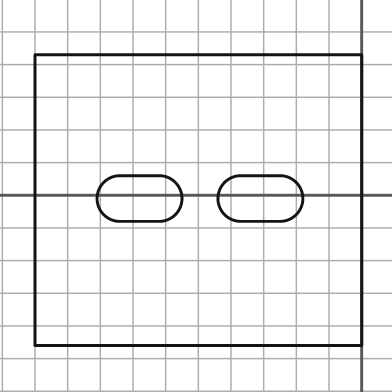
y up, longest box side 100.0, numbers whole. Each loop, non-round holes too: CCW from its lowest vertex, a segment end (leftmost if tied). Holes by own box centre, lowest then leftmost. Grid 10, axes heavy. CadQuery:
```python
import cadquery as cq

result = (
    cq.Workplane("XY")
    .moveTo(-100.0, -46.0)
    .lineTo(0.0, -46.0)
    .lineTo(0.0, 43.0)
    .lineTo(-100.0, 43.0)
    .close()
    .moveTo(-74.0, -8.0)
    .lineTo(-62.0, -8.0)
    .threePointArc((-55.0, -1.0), (-62.0, 6.0))
    .lineTo(-74.0, 6.0)
    .threePointArc((-81.0, -1.0), (-74.0, -8.0))
    .close()
    .moveTo(-37.0, -8.0)
    .lineTo(-25.0, -8.0)
    .threePointArc((-18.0, -1.0), (-25.0, 6.0))
    .lineTo(-37.0, 6.0)
    .threePointArc((-44.0, -1.0), (-37.0, -8.0))
    .close()
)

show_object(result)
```